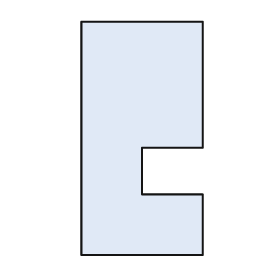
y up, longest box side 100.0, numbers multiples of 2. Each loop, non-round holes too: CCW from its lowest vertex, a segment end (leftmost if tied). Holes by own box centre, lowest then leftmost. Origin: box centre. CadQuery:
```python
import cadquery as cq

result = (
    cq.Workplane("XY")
    .moveTo(-26.0, -50.0)
    .lineTo(26.0, -50.0)
    .lineTo(26.0, -24.0)
    .lineTo(0.0, -24.0)
    .lineTo(0.0, -4.0)
    .lineTo(26.0, -4.0)
    .lineTo(26.0, 50.0)
    .lineTo(-26.0, 50.0)
    .close()
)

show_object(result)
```